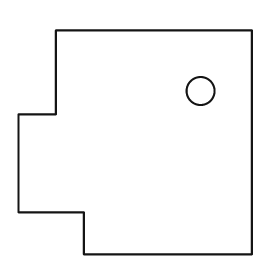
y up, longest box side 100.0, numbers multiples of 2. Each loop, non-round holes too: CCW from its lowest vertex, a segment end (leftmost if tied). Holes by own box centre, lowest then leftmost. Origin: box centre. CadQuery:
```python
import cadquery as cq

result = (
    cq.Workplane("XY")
    .moveTo(-22.0, -48.0)
    .lineTo(50.0, -48.0)
    .lineTo(50.0, 48.0)
    .lineTo(-34.0, 48.0)
    .lineTo(-34.0, 12.0)
    .lineTo(-50.0, 12.0)
    .lineTo(-50.0, -30.0)
    .lineTo(-22.0, -30.0)
    .close()
    .moveTo(28.0, 22.0)
    .circle(6.0)
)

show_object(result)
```